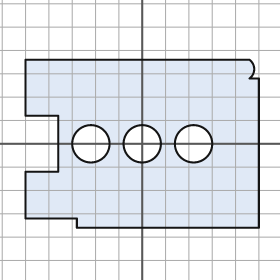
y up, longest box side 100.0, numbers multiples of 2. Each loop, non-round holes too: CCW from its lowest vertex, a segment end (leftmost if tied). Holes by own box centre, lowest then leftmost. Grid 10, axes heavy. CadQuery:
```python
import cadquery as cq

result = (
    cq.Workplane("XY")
    .moveTo(-28.0, -36.0)
    .lineTo(50.0, -36.0)
    .lineTo(50.0, 28.0)
    .lineTo(46.0, 28.0)
    .threePointArc((48.0, 32.0), (46.0, 36.0))
    .lineTo(-50.0, 36.0)
    .lineTo(-50.0, 12.0)
    .lineTo(-36.0, 12.0)
    .lineTo(-36.0, -12.0)
    .lineTo(-50.0, -12.0)
    .lineTo(-50.0, -32.0)
    .lineTo(-28.0, -32.0)
    .close()
    .moveTo(-22.0, 0.0)
    .circle(8.0)
    .moveTo(0.0, 0.0)
    .circle(8.0)
    .moveTo(22.0, 0.0)
    .circle(8.0)
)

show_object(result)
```